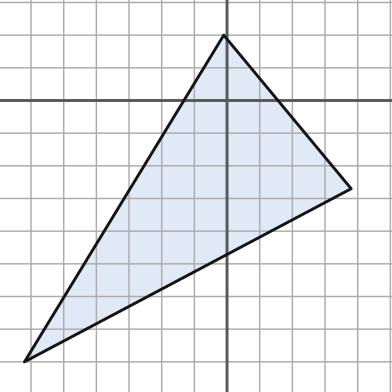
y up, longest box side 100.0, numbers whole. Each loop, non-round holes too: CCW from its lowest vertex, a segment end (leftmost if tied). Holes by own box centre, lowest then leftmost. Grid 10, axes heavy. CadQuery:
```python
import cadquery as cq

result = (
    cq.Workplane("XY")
    .moveTo(-62.0, -80.0)
    .lineTo(38.0, -27.0)
    .lineTo(-1.0, 20.0)
    .close()
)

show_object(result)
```